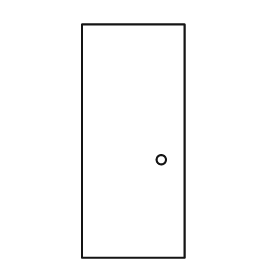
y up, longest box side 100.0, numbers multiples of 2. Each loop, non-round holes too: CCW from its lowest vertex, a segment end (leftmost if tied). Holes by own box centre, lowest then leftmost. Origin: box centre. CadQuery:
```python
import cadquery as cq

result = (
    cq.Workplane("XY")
    .moveTo(-22.0, -50.0)
    .lineTo(22.0, -50.0)
    .lineTo(22.0, 50.0)
    .lineTo(-22.0, 50.0)
    .close()
    .moveTo(12.0, -8.0)
    .circle(2.0)
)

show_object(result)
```